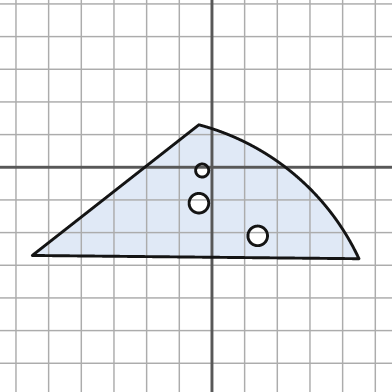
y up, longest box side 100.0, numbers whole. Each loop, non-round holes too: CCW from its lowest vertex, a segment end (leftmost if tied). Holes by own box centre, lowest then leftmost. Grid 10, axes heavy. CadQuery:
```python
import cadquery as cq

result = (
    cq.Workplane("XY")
    .moveTo(45.0, -28.0)
    .threePointArc((25.0, -2.0), (-4.0, 13.0))
    .lineTo(-55.0, -27.0)
    .close()
    .moveTo(14.0, -21.0)
    .circle(3.0)
    .moveTo(-4.0, -11.0)
    .circle(3.0)
    .moveTo(-3.0, -1.0)
    .circle(2.0)
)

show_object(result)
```